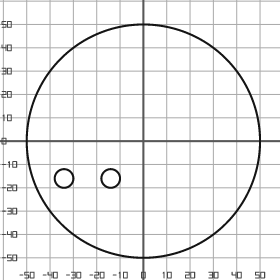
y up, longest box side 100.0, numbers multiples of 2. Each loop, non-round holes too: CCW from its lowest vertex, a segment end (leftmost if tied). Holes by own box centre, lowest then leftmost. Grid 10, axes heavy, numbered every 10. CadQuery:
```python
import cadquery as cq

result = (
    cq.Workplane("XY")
    .moveTo(0.0, 0.0)
    .circle(50.0)
    .moveTo(-34.0, -16.0)
    .circle(4.0)
    .moveTo(-14.0, -16.0)
    .circle(4.0)
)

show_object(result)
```